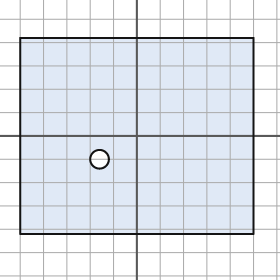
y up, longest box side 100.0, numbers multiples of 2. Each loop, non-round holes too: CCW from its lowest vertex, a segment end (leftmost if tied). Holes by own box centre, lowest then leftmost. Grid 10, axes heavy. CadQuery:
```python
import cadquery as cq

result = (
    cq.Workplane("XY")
    .moveTo(-50.0, -42.0)
    .lineTo(50.0, -42.0)
    .lineTo(50.0, 42.0)
    .lineTo(-50.0, 42.0)
    .close()
    .moveTo(-16.0, -10.0)
    .circle(4.0)
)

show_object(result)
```